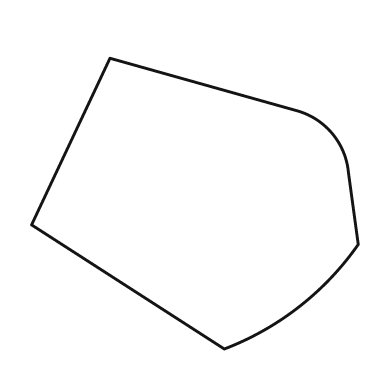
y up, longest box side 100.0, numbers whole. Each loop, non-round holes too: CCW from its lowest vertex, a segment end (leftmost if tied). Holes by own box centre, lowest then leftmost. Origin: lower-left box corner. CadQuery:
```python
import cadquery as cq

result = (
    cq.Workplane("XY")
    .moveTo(59.0, 0.0)
    .threePointArc((82.0, 13.0), (100.0, 32.0))
    .lineTo(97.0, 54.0)
    .threePointArc((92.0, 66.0), (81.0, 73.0))
    .lineTo(24.0, 89.0)
    .lineTo(0.0, 38.0)
    .close()
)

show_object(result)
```